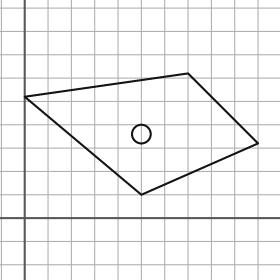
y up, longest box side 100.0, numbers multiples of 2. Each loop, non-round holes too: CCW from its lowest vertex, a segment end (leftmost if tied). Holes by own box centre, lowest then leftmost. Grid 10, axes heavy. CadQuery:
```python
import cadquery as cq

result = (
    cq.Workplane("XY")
    .moveTo(50.0, 10.0)
    .lineTo(100.0, 32.0)
    .lineTo(70.0, 62.0)
    .lineTo(0.0, 52.0)
    .close()
    .moveTo(50.0, 36.0)
    .circle(4.0)
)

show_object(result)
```